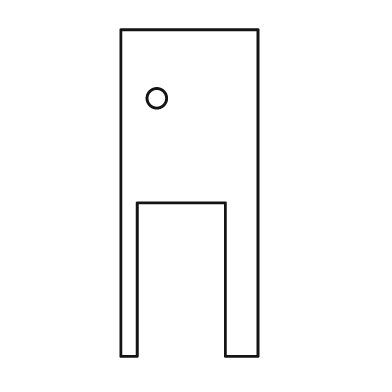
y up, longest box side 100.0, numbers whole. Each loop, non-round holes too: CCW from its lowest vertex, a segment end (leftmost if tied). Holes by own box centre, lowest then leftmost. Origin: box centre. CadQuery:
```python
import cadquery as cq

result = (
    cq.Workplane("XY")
    .moveTo(-21.0, -50.0)
    .lineTo(-16.0, -50.0)
    .lineTo(-16.0, -3.0)
    .lineTo(11.0, -3.0)
    .lineTo(11.0, -50.0)
    .lineTo(21.0, -50.0)
    .lineTo(21.0, 50.0)
    .lineTo(-21.0, 50.0)
    .close()
    .moveTo(-10.0, 29.0)
    .circle(3.0)
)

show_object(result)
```